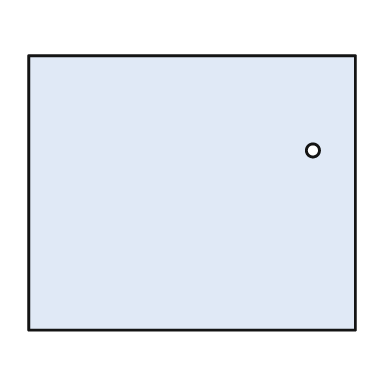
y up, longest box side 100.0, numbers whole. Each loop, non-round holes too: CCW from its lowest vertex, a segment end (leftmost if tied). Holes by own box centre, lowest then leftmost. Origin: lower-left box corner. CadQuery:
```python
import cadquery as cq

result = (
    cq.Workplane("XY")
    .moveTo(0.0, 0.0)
    .lineTo(100.0, 0.0)
    .lineTo(100.0, 84.0)
    .lineTo(0.0, 84.0)
    .close()
    .moveTo(87.0, 55.0)
    .circle(2.0)
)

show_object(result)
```